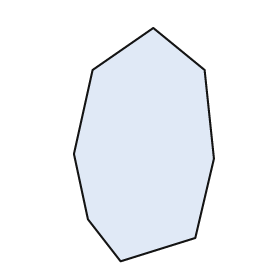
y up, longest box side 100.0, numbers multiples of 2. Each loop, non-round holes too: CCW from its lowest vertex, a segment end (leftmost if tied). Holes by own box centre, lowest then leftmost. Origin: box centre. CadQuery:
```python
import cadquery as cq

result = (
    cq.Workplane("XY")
    .moveTo(-10.0, -50.0)
    .lineTo(22.0, -40.0)
    .lineTo(30.0, -6.0)
    .lineTo(26.0, 32.0)
    .lineTo(4.0, 50.0)
    .lineTo(-22.0, 32.0)
    .lineTo(-30.0, -4.0)
    .lineTo(-24.0, -32.0)
    .close()
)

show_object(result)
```